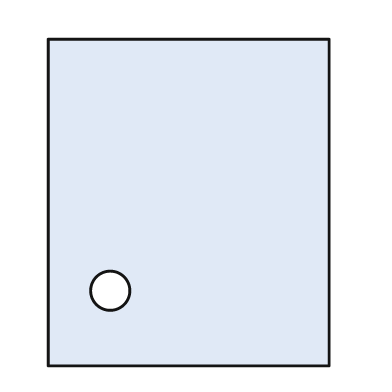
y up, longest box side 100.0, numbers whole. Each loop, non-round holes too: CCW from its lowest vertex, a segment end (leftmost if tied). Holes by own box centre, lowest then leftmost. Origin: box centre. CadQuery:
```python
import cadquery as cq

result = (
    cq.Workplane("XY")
    .moveTo(-43.0, -50.0)
    .lineTo(43.0, -50.0)
    .lineTo(43.0, 50.0)
    .lineTo(-43.0, 50.0)
    .close()
    .moveTo(-24.0, -27.0)
    .circle(6.0)
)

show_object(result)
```